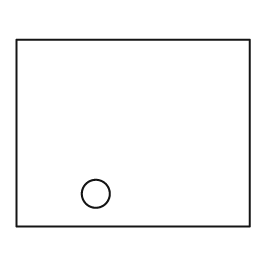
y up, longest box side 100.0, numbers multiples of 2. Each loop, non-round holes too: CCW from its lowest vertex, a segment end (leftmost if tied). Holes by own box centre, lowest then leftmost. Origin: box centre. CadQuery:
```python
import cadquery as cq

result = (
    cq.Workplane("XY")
    .moveTo(-50.0, -40.0)
    .lineTo(50.0, -40.0)
    .lineTo(50.0, 40.0)
    .lineTo(-50.0, 40.0)
    .close()
    .moveTo(-16.0, -26.0)
    .circle(6.0)
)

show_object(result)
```